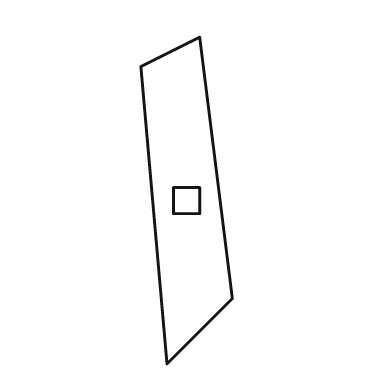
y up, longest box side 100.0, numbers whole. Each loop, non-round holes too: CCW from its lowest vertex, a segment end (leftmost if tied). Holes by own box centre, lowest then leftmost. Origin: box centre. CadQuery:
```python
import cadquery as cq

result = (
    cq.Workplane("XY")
    .moveTo(-6.0, -50.0)
    .lineTo(14.0, -30.0)
    .lineTo(4.0, 50.0)
    .lineTo(-14.0, 41.0)
    .close()
    .moveTo(-4.0, -4.0)
    .lineTo(4.0, -4.0)
    .lineTo(4.0, 4.0)
    .lineTo(-4.0, 4.0)
    .close()
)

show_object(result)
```